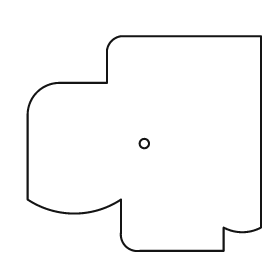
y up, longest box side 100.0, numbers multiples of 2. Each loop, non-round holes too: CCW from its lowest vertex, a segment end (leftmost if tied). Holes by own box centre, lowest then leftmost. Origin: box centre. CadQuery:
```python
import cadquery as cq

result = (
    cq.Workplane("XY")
    .moveTo(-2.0, -46.0)
    .lineTo(34.0, -46.0)
    .lineTo(34.0, -36.0)
    .threePointArc((42.0, -38.0), (50.0, -36.0))
    .lineTo(50.0, 46.0)
    .lineTo(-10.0, 46.0)
    .threePointArc((-14.0, 44.0), (-16.0, 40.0))
    .lineTo(-16.0, 26.0)
    .lineTo(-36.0, 26.0)
    .threePointArc((-46.0, 22.0), (-50.0, 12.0))
    .lineTo(-50.0, -24.0)
    .threePointArc((-30.0, -30.0), (-10.0, -24.0))
    .lineTo(-10.0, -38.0)
    .threePointArc((-8.0, -44.0), (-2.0, -46.0))
    .close()
    .moveTo(0.0, 0.0)
    .circle(2.0)
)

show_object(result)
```